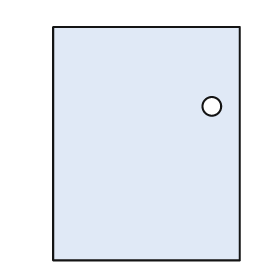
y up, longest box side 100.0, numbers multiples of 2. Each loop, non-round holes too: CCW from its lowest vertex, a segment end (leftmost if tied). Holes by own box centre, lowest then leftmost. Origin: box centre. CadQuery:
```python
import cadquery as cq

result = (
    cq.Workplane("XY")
    .moveTo(-40.0, -50.0)
    .lineTo(40.0, -50.0)
    .lineTo(40.0, 50.0)
    .lineTo(-40.0, 50.0)
    .close()
    .moveTo(28.0, 16.0)
    .circle(4.0)
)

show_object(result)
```